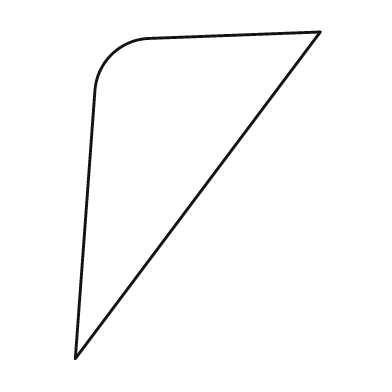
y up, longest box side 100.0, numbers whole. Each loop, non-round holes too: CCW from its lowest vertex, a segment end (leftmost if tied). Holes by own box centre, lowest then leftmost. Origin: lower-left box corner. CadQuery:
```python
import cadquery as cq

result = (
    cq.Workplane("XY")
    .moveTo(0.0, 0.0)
    .lineTo(75.0, 100.0)
    .lineTo(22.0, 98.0)
    .threePointArc((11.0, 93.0), (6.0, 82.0))
    .close()
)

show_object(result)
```